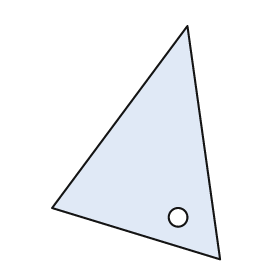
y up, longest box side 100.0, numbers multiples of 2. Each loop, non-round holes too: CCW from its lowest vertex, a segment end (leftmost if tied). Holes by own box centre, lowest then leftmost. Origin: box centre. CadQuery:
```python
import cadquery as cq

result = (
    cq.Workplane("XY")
    .moveTo(36.0, -50.0)
    .lineTo(22.0, 50.0)
    .lineTo(-36.0, -28.0)
    .close()
    .moveTo(18.0, -32.0)
    .circle(4.0)
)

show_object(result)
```